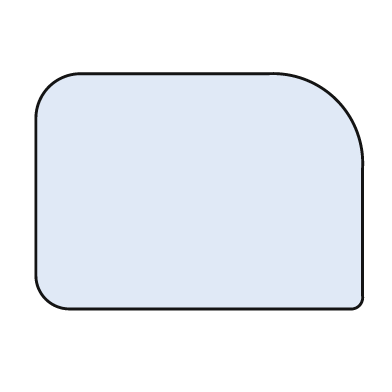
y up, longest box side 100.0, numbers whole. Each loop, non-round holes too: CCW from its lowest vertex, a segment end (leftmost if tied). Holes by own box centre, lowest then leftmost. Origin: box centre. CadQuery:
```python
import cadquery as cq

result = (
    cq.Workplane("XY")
    .moveTo(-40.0, -36.0)
    .lineTo(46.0, -36.0)
    .threePointArc((49.0, -35.0), (50.0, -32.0))
    .lineTo(50.0, 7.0)
    .threePointArc((42.0, 28.0), (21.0, 36.0))
    .lineTo(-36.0, 36.0)
    .threePointArc((-46.0, 32.0), (-50.0, 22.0))
    .lineTo(-50.0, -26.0)
    .threePointArc((-47.0, -33.0), (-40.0, -36.0))
    .close()
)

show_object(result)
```